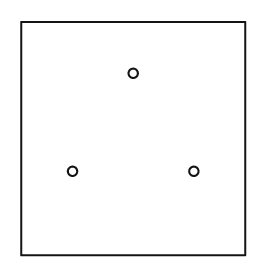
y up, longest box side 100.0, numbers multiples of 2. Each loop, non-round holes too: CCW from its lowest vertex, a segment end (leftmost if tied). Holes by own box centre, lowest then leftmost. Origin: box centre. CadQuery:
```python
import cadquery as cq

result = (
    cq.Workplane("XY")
    .moveTo(-48.0, -50.0)
    .lineTo(48.0, -50.0)
    .lineTo(48.0, 50.0)
    .lineTo(-48.0, 50.0)
    .close()
    .moveTo(-26.0, -14.0)
    .circle(2.0)
    .moveTo(26.0, -14.0)
    .circle(2.0)
    .moveTo(0.0, 28.0)
    .circle(2.0)
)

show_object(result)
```